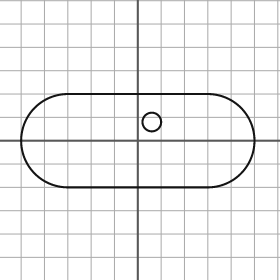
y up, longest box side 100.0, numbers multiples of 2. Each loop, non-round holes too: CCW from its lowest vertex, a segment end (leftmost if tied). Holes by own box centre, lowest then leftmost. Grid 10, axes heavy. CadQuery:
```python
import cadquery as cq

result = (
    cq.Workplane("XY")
    .moveTo(-30.0, -20.0)
    .lineTo(30.0, -20.0)
    .threePointArc((50.0, 0.0), (30.0, 20.0))
    .lineTo(-30.0, 20.0)
    .threePointArc((-50.0, 0.0), (-30.0, -20.0))
    .close()
    .moveTo(6.0, 8.0)
    .circle(4.0)
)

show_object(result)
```